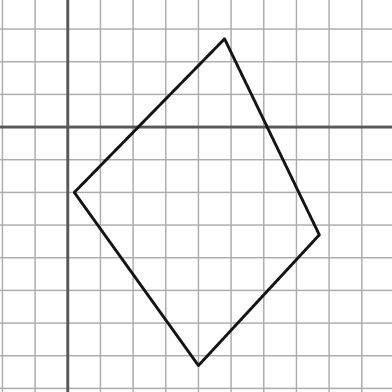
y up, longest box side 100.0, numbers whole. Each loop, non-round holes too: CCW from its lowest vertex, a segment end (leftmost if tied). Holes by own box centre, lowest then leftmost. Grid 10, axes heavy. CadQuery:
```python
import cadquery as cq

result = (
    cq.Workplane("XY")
    .moveTo(40.0, -73.0)
    .lineTo(77.0, -33.0)
    .lineTo(48.0, 27.0)
    .lineTo(2.0, -20.0)
    .close()
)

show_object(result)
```